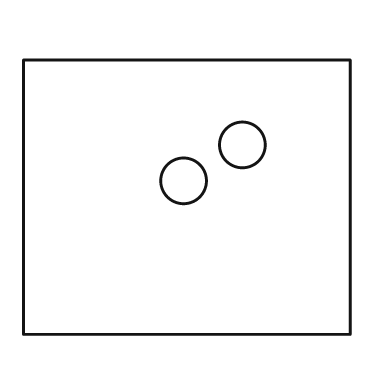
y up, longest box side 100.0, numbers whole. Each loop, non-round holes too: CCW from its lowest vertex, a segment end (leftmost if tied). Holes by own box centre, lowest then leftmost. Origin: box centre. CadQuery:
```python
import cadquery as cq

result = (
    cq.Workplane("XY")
    .moveTo(-50.0, -42.0)
    .lineTo(50.0, -42.0)
    .lineTo(50.0, 42.0)
    .lineTo(-50.0, 42.0)
    .close()
    .moveTo(-1.0, 5.0)
    .circle(7.0)
    .moveTo(17.0, 16.0)
    .circle(7.0)
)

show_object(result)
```